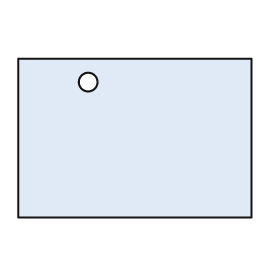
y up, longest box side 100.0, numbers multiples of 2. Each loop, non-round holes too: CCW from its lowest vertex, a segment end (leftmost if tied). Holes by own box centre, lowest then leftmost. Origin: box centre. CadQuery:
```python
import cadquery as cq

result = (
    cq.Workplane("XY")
    .moveTo(-50.0, -34.0)
    .lineTo(50.0, -34.0)
    .lineTo(50.0, 34.0)
    .lineTo(-50.0, 34.0)
    .close()
    .moveTo(-20.0, 24.0)
    .circle(4.0)
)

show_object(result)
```